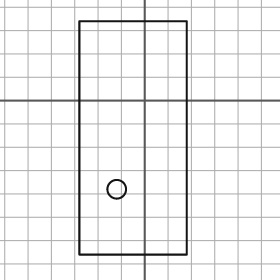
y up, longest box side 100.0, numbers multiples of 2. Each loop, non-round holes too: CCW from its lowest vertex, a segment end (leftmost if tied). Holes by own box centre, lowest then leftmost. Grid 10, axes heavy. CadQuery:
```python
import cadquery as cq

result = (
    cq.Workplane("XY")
    .moveTo(-28.0, -66.0)
    .lineTo(18.0, -66.0)
    .lineTo(18.0, 34.0)
    .lineTo(-28.0, 34.0)
    .close()
    .moveTo(-12.0, -38.0)
    .circle(4.0)
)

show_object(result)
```